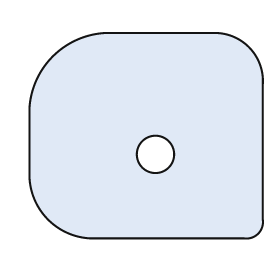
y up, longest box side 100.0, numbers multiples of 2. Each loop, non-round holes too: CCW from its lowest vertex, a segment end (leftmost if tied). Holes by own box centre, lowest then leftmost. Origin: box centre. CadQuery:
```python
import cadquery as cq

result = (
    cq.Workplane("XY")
    .moveTo(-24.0, -44.0)
    .lineTo(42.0, -44.0)
    .threePointArc((48.0, -42.0), (50.0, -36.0))
    .lineTo(50.0, 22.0)
    .threePointArc((44.0, 38.0), (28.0, 44.0))
    .lineTo(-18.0, 44.0)
    .threePointArc((-40.0, 34.0), (-50.0, 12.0))
    .lineTo(-50.0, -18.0)
    .threePointArc((-42.0, -36.0), (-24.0, -44.0))
    .close()
    .moveTo(4.0, -8.0)
    .circle(8.0)
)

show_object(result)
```